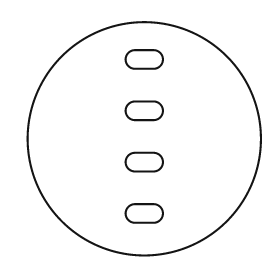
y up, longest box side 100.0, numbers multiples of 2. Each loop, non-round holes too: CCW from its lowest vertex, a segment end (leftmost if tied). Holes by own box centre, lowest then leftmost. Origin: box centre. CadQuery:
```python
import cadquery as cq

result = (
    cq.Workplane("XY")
    .moveTo(0.0, 0.0)
    .circle(50.0)
    .moveTo(-4.0, -36.0)
    .lineTo(4.0, -36.0)
    .threePointArc((8.0, -32.0), (4.0, -28.0))
    .lineTo(-4.0, -28.0)
    .threePointArc((-8.0, -32.0), (-4.0, -36.0))
    .close()
    .moveTo(-4.0, -14.0)
    .lineTo(4.0, -14.0)
    .threePointArc((8.0, -10.0), (4.0, -6.0))
    .lineTo(-4.0, -6.0)
    .threePointArc((-8.0, -10.0), (-4.0, -14.0))
    .close()
    .moveTo(-4.0, 8.0)
    .lineTo(4.0, 8.0)
    .threePointArc((8.0, 12.0), (4.0, 16.0))
    .lineTo(-4.0, 16.0)
    .threePointArc((-8.0, 12.0), (-4.0, 8.0))
    .close()
    .moveTo(-4.0, 30.0)
    .lineTo(4.0, 30.0)
    .threePointArc((8.0, 34.0), (4.0, 38.0))
    .lineTo(-4.0, 38.0)
    .threePointArc((-8.0, 34.0), (-4.0, 30.0))
    .close()
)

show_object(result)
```